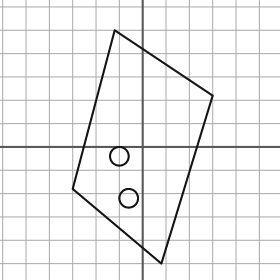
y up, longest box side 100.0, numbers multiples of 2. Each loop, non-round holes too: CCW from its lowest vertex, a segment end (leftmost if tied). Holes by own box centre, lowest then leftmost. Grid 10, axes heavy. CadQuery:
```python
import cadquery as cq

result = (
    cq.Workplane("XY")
    .moveTo(8.0, -50.0)
    .lineTo(30.0, 22.0)
    .lineTo(-12.0, 50.0)
    .lineTo(-30.0, -18.0)
    .close()
    .moveTo(-6.0, -22.0)
    .circle(4.0)
    .moveTo(-10.0, -4.0)
    .circle(4.0)
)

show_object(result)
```